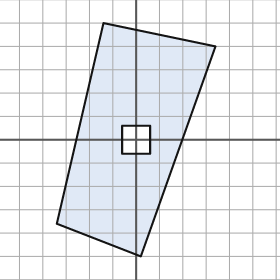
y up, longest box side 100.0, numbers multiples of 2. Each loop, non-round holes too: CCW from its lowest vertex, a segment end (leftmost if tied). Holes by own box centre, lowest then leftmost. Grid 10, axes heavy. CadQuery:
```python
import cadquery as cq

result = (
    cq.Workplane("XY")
    .moveTo(2.0, -50.0)
    .lineTo(34.0, 40.0)
    .lineTo(-14.0, 50.0)
    .lineTo(-34.0, -36.0)
    .close()
    .moveTo(-6.0, -6.0)
    .lineTo(6.0, -6.0)
    .lineTo(6.0, 6.0)
    .lineTo(-6.0, 6.0)
    .close()
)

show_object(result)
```